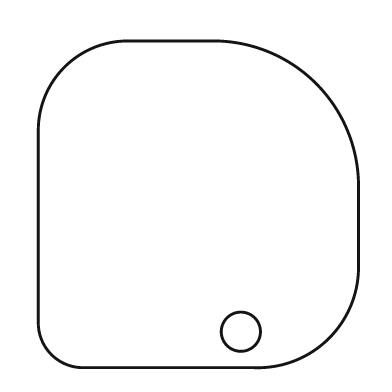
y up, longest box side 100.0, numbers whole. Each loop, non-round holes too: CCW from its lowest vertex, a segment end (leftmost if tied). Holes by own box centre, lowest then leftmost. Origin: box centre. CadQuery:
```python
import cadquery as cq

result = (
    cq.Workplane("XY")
    .moveTo(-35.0, -50.0)
    .lineTo(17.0, -50.0)
    .threePointArc((40.0, -41.0), (49.0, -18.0))
    .lineTo(49.0, 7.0)
    .threePointArc((36.0, 37.0), (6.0, 50.0))
    .lineTo(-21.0, 50.0)
    .threePointArc((-41.0, 42.0), (-49.0, 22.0))
    .lineTo(-49.0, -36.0)
    .threePointArc((-45.0, -46.0), (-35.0, -50.0))
    .close()
    .moveTo(13.0, -39.0)
    .circle(6.0)
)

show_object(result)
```